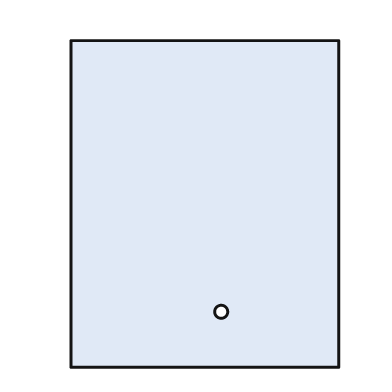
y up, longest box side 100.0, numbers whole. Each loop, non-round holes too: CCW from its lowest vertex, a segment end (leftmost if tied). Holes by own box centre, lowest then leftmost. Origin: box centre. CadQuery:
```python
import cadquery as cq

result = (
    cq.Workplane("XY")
    .moveTo(-41.0, -50.0)
    .lineTo(41.0, -50.0)
    .lineTo(41.0, 50.0)
    .lineTo(-41.0, 50.0)
    .close()
    .moveTo(5.0, -33.0)
    .circle(2.0)
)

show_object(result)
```